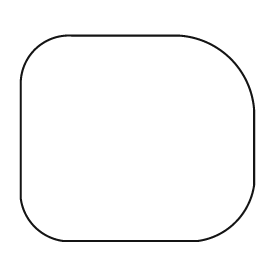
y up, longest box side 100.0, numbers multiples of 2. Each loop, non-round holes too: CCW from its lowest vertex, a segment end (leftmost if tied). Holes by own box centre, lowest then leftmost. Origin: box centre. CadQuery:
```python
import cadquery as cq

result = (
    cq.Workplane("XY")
    .moveTo(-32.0, -44.0)
    .lineTo(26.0, -44.0)
    .threePointArc((42.0, -36.0), (50.0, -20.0))
    .lineTo(50.0, 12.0)
    .threePointArc((40.0, 34.0), (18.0, 44.0))
    .lineTo(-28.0, 44.0)
    .threePointArc((-44.0, 38.0), (-50.0, 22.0))
    .lineTo(-50.0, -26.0)
    .threePointArc((-44.0, -38.0), (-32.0, -44.0))
    .close()
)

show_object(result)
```